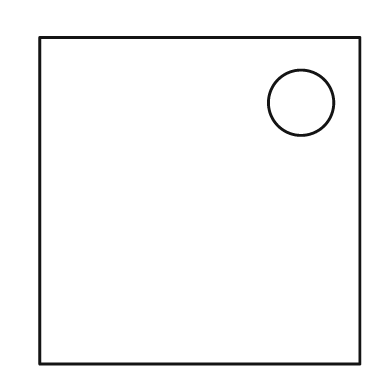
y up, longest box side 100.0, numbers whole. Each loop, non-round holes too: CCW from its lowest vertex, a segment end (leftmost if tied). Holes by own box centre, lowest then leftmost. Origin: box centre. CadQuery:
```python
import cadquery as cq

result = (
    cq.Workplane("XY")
    .moveTo(-49.0, -50.0)
    .lineTo(49.0, -50.0)
    .lineTo(49.0, 50.0)
    .lineTo(-49.0, 50.0)
    .close()
    .moveTo(31.0, 30.0)
    .circle(10.0)
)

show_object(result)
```